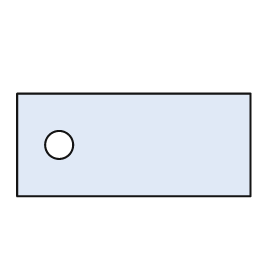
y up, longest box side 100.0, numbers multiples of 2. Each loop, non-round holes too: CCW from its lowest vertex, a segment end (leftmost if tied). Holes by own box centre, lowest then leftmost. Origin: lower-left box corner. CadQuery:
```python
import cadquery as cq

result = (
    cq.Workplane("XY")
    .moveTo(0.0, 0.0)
    .lineTo(100.0, 0.0)
    .lineTo(100.0, 44.0)
    .lineTo(0.0, 44.0)
    .close()
    .moveTo(18.0, 22.0)
    .circle(6.0)
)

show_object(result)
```